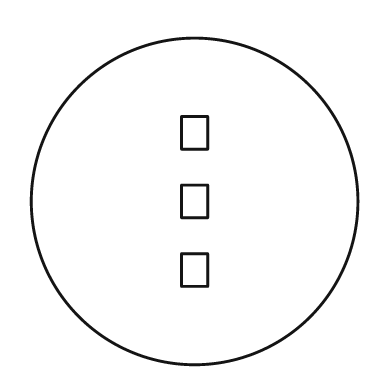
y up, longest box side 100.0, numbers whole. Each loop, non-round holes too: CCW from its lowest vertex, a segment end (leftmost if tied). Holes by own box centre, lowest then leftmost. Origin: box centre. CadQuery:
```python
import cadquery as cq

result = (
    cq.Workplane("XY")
    .moveTo(0.0, 0.0)
    .circle(50.0)
    .moveTo(-4.0, -26.0)
    .lineTo(4.0, -26.0)
    .lineTo(4.0, -16.0)
    .lineTo(-4.0, -16.0)
    .close()
    .moveTo(-4.0, -5.0)
    .lineTo(4.0, -5.0)
    .lineTo(4.0, 5.0)
    .lineTo(-4.0, 5.0)
    .close()
    .moveTo(-4.0, 16.0)
    .lineTo(4.0, 16.0)
    .lineTo(4.0, 26.0)
    .lineTo(-4.0, 26.0)
    .close()
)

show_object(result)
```